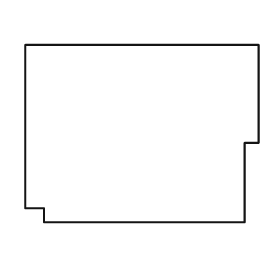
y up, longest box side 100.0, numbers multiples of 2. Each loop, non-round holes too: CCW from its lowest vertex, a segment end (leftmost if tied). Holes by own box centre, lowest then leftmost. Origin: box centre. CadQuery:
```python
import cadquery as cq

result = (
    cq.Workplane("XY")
    .moveTo(-42.0, -38.0)
    .lineTo(44.0, -38.0)
    .lineTo(44.0, -4.0)
    .lineTo(50.0, -4.0)
    .lineTo(50.0, 38.0)
    .lineTo(-50.0, 38.0)
    .lineTo(-50.0, -32.0)
    .lineTo(-42.0, -32.0)
    .close()
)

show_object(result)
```